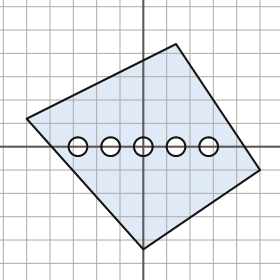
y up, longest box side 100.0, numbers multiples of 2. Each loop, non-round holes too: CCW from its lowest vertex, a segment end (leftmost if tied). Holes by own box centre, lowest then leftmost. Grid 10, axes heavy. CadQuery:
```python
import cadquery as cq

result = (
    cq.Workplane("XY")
    .moveTo(0.0, -44.0)
    .lineTo(50.0, -10.0)
    .lineTo(14.0, 44.0)
    .lineTo(-50.0, 12.0)
    .close()
    .moveTo(-28.0, 0.0)
    .circle(4.0)
    .moveTo(-14.0, 0.0)
    .circle(4.0)
    .moveTo(0.0, 0.0)
    .circle(4.0)
    .moveTo(14.0, 0.0)
    .circle(4.0)
    .moveTo(28.0, 0.0)
    .circle(4.0)
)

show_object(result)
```